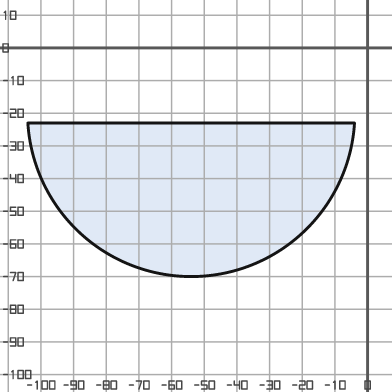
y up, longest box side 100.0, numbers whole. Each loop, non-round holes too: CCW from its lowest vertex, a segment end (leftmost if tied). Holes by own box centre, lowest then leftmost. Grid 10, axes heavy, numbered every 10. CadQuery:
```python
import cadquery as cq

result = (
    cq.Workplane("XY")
    .moveTo(-104.0, -23.0)
    .threePointArc((-54.0, -70.0), (-4.0, -23.0))
    .close()
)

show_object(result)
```